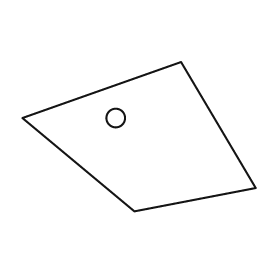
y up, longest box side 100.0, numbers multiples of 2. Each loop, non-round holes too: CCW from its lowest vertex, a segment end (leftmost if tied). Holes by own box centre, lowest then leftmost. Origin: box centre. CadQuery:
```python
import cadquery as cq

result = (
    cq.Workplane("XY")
    .moveTo(-2.0, -32.0)
    .lineTo(50.0, -22.0)
    .lineTo(18.0, 32.0)
    .lineTo(-50.0, 8.0)
    .close()
    .moveTo(-10.0, 8.0)
    .circle(4.0)
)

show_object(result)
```